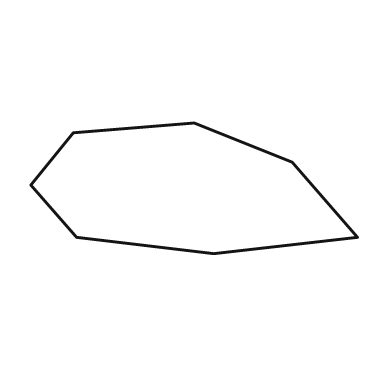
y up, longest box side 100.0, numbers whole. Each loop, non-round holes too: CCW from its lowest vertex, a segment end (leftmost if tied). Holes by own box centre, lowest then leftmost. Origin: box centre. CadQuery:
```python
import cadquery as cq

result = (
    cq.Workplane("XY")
    .moveTo(6.0, -20.0)
    .lineTo(50.0, -15.0)
    .lineTo(30.0, 8.0)
    .lineTo(0.0, 20.0)
    .lineTo(-37.0, 17.0)
    .lineTo(-50.0, 1.0)
    .lineTo(-36.0, -15.0)
    .close()
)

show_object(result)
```